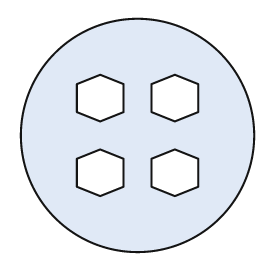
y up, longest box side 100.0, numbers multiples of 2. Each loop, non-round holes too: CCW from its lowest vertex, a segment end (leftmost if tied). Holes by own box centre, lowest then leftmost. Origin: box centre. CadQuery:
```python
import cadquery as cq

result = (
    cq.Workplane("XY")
    .moveTo(0.0, 0.0)
    .circle(50.0)
    .moveTo(-16.0, -26.0)
    .lineTo(-6.0, -22.0)
    .lineTo(-6.0, -10.0)
    .lineTo(-16.0, -6.0)
    .lineTo(-26.0, -10.0)
    .lineTo(-26.0, -22.0)
    .close()
    .moveTo(16.0, -26.0)
    .lineTo(26.0, -22.0)
    .lineTo(26.0, -10.0)
    .lineTo(16.0, -6.0)
    .lineTo(6.0, -10.0)
    .lineTo(6.0, -22.0)
    .close()
    .moveTo(-16.0, 6.0)
    .lineTo(-6.0, 10.0)
    .lineTo(-6.0, 22.0)
    .lineTo(-16.0, 26.0)
    .lineTo(-26.0, 22.0)
    .lineTo(-26.0, 10.0)
    .close()
    .moveTo(16.0, 6.0)
    .lineTo(26.0, 10.0)
    .lineTo(26.0, 22.0)
    .lineTo(16.0, 26.0)
    .lineTo(6.0, 22.0)
    .lineTo(6.0, 10.0)
    .close()
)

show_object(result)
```